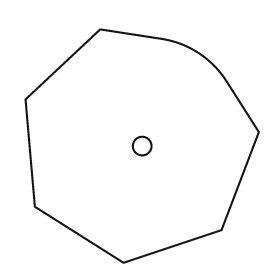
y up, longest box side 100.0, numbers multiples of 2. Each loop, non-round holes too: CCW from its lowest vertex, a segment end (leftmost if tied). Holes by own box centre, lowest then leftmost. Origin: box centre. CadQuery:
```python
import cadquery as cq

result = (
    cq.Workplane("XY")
    .moveTo(-8.0, -50.0)
    .lineTo(34.0, -36.0)
    .lineTo(50.0, 6.0)
    .lineTo(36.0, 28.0)
    .threePointArc((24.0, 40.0), (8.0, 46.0))
    .lineTo(-18.0, 50.0)
    .lineTo(-50.0, 20.0)
    .lineTo(-46.0, -26.0)
    .close()
    .moveTo(0.0, 0.0)
    .circle(4.0)
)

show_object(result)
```